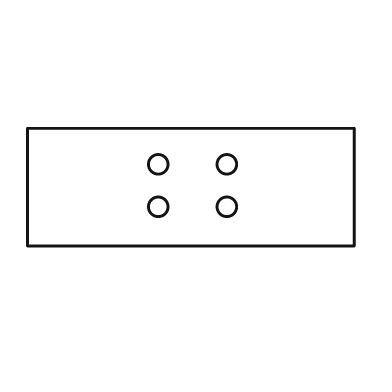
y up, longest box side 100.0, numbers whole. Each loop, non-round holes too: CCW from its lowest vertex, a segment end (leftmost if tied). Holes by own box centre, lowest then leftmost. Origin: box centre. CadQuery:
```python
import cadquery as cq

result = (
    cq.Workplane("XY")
    .moveTo(-50.0, -18.0)
    .lineTo(50.0, -18.0)
    .lineTo(50.0, 18.0)
    .lineTo(-50.0, 18.0)
    .close()
    .moveTo(-10.0, -6.0)
    .circle(3.0)
    .moveTo(11.0, -6.0)
    .circle(3.0)
    .moveTo(-10.0, 7.0)
    .circle(3.0)
    .moveTo(11.0, 7.0)
    .circle(3.0)
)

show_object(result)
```